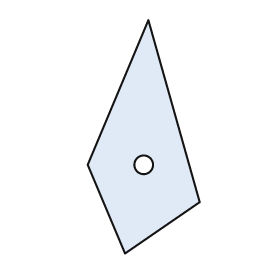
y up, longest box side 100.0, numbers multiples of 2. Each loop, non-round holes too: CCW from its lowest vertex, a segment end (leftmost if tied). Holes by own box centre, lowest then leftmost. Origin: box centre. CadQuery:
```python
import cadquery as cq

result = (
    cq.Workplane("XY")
    .moveTo(-8.0, -50.0)
    .lineTo(24.0, -28.0)
    .lineTo(2.0, 50.0)
    .lineTo(-24.0, -12.0)
    .close()
    .moveTo(0.0, -12.0)
    .circle(4.0)
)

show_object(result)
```